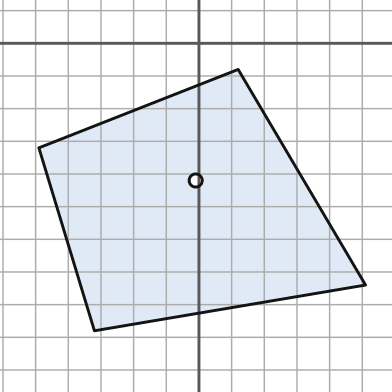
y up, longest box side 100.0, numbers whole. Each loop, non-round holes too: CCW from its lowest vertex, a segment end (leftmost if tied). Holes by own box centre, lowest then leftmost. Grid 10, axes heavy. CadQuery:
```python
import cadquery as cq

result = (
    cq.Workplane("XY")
    .moveTo(-32.0, -88.0)
    .lineTo(51.0, -74.0)
    .lineTo(12.0, -8.0)
    .lineTo(-49.0, -32.0)
    .close()
    .moveTo(-1.0, -42.0)
    .circle(2.0)
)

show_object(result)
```